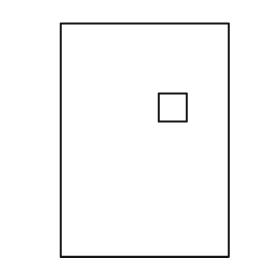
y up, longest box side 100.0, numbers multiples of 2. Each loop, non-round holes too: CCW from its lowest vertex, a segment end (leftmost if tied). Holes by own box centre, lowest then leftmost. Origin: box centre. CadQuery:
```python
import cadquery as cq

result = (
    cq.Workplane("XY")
    .moveTo(-36.0, -50.0)
    .lineTo(36.0, -50.0)
    .lineTo(36.0, 50.0)
    .lineTo(-36.0, 50.0)
    .close()
    .moveTo(6.0, 8.0)
    .lineTo(18.0, 8.0)
    .lineTo(18.0, 20.0)
    .lineTo(6.0, 20.0)
    .close()
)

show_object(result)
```